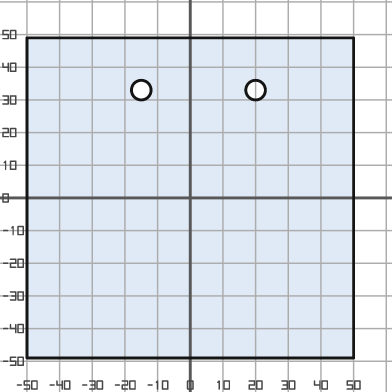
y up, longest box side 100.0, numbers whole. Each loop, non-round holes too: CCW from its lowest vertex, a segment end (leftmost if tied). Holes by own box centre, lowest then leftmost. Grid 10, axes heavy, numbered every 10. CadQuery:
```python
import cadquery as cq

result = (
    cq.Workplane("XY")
    .moveTo(-50.0, -49.0)
    .lineTo(50.0, -49.0)
    .lineTo(50.0, 49.0)
    .lineTo(-50.0, 49.0)
    .close()
    .moveTo(-15.0, 33.0)
    .circle(3.0)
    .moveTo(20.0, 33.0)
    .circle(3.0)
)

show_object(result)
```